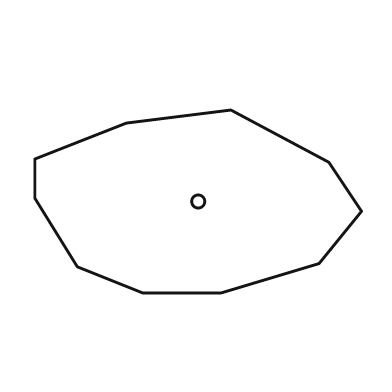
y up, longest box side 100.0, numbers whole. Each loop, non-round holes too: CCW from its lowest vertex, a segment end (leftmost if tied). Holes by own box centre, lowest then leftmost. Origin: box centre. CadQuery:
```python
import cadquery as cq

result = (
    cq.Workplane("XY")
    .moveTo(-17.0, -28.0)
    .lineTo(7.0, -28.0)
    .lineTo(37.0, -19.0)
    .lineTo(50.0, -3.0)
    .lineTo(40.0, 12.0)
    .lineTo(10.0, 28.0)
    .lineTo(-22.0, 24.0)
    .lineTo(-50.0, 13.0)
    .lineTo(-50.0, 1.0)
    .lineTo(-37.0, -20.0)
    .close()
    .moveTo(0.0, 0.0)
    .circle(2.0)
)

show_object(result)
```